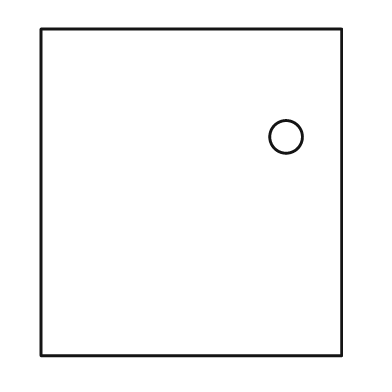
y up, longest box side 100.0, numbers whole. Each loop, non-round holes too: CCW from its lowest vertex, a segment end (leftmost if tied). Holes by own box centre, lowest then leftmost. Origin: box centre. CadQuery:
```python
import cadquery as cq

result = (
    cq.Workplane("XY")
    .moveTo(-46.0, -50.0)
    .lineTo(46.0, -50.0)
    .lineTo(46.0, 50.0)
    .lineTo(-46.0, 50.0)
    .close()
    .moveTo(29.0, 17.0)
    .circle(5.0)
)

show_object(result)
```